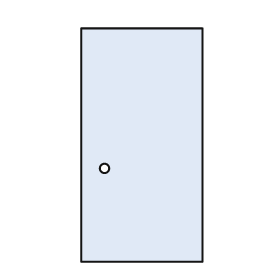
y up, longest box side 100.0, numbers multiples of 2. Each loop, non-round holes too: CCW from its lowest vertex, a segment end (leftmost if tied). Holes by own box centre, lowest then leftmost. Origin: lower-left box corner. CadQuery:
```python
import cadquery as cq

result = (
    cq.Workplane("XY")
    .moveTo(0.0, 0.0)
    .lineTo(52.0, 0.0)
    .lineTo(52.0, 100.0)
    .lineTo(0.0, 100.0)
    .close()
    .moveTo(10.0, 40.0)
    .circle(2.0)
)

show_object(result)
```